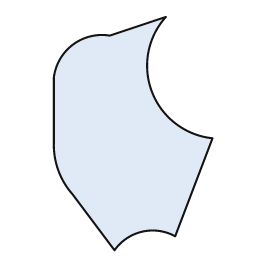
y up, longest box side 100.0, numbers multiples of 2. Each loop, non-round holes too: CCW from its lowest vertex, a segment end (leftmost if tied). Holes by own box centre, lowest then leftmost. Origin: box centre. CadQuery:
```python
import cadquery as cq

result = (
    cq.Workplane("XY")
    .moveTo(-8.0, -50.0)
    .threePointArc((4.0, -42.0), (18.0, -44.0))
    .lineTo(34.0, -2.0)
    .threePointArc((8.0, 18.0), (14.0, 50.0))
    .lineTo(-10.0, 42.0)
    .threePointArc((-26.0, 38.0), (-34.0, 24.0))
    .lineTo(-34.0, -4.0)
    .threePointArc((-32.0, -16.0), (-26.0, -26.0))
    .close()
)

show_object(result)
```